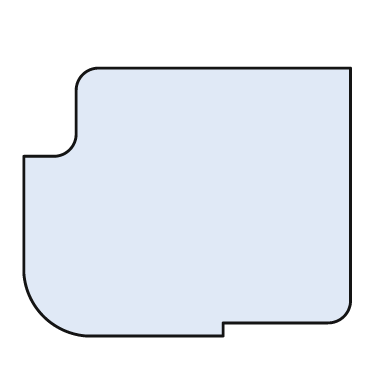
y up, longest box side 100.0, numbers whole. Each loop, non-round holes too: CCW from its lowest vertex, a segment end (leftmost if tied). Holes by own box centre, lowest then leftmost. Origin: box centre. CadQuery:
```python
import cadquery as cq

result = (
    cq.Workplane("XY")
    .moveTo(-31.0, -41.0)
    .lineTo(11.0, -41.0)
    .lineTo(11.0, -37.0)
    .lineTo(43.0, -37.0)
    .threePointArc((48.0, -35.0), (50.0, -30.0))
    .lineTo(50.0, 41.0)
    .lineTo(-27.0, 41.0)
    .threePointArc((-32.0, 39.0), (-34.0, 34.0))
    .lineTo(-34.0, 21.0)
    .threePointArc((-36.0, 16.0), (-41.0, 14.0))
    .lineTo(-50.0, 14.0)
    .lineTo(-50.0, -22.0)
    .threePointArc((-44.0, -35.0), (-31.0, -41.0))
    .close()
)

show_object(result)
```